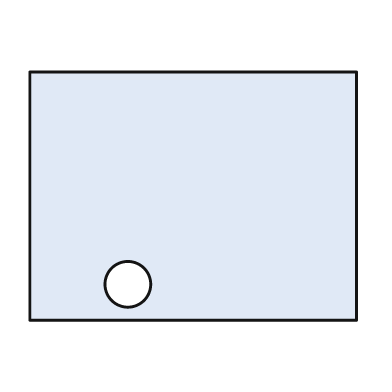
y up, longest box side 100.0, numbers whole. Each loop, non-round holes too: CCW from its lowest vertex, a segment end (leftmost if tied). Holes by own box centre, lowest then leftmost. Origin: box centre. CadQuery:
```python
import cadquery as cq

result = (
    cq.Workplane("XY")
    .moveTo(-50.0, -38.0)
    .lineTo(50.0, -38.0)
    .lineTo(50.0, 38.0)
    .lineTo(-50.0, 38.0)
    .close()
    .moveTo(-20.0, -27.0)
    .circle(7.0)
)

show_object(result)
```